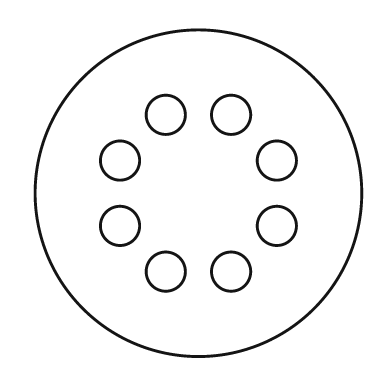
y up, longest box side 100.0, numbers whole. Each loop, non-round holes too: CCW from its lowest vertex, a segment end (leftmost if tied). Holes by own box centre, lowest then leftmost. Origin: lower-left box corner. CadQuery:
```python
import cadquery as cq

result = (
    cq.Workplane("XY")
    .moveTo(50.0, 50.0)
    .circle(50.0)
    .moveTo(40.0, 26.0)
    .circle(6.0)
    .moveTo(60.0, 26.0)
    .circle(6.0)
    .moveTo(26.0, 40.0)
    .circle(6.0)
    .moveTo(74.0, 40.0)
    .circle(6.0)
    .moveTo(26.0, 60.0)
    .circle(6.0)
    .moveTo(74.0, 60.0)
    .circle(6.0)
    .moveTo(40.0, 74.0)
    .circle(6.0)
    .moveTo(60.0, 74.0)
    .circle(6.0)
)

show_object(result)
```